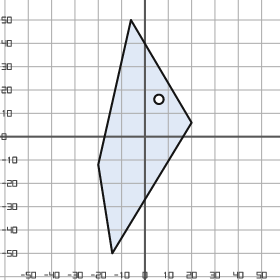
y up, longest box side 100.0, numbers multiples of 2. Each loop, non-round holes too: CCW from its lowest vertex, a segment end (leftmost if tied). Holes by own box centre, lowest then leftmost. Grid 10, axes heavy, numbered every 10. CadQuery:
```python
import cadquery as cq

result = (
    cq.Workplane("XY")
    .moveTo(-14.0, -50.0)
    .lineTo(20.0, 6.0)
    .lineTo(-6.0, 50.0)
    .lineTo(-20.0, -12.0)
    .close()
    .moveTo(6.0, 16.0)
    .circle(2.0)
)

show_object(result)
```